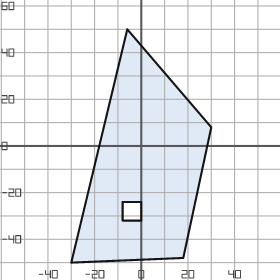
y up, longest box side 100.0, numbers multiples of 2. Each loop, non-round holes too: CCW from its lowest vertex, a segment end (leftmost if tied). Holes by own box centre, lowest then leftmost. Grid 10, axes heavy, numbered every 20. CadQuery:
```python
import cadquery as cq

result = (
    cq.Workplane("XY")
    .moveTo(-30.0, -50.0)
    .lineTo(18.0, -48.0)
    .lineTo(30.0, 8.0)
    .lineTo(-6.0, 50.0)
    .close()
    .moveTo(-8.0, -32.0)
    .lineTo(0.0, -32.0)
    .lineTo(0.0, -24.0)
    .lineTo(-8.0, -24.0)
    .close()
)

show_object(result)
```